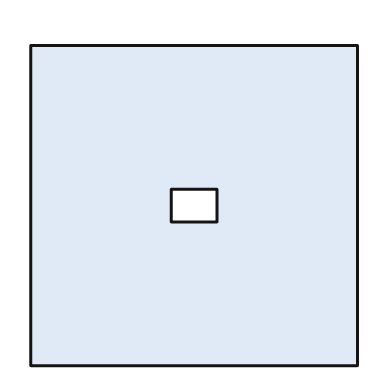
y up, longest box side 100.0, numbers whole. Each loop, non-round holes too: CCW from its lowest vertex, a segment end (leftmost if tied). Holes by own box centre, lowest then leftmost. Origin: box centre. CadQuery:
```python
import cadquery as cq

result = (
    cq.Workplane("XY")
    .moveTo(-50.0, -49.0)
    .lineTo(50.0, -49.0)
    .lineTo(50.0, 49.0)
    .lineTo(-50.0, 49.0)
    .close()
    .moveTo(-7.0, -5.0)
    .lineTo(7.0, -5.0)
    .lineTo(7.0, 5.0)
    .lineTo(-7.0, 5.0)
    .close()
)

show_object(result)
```